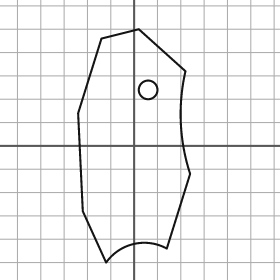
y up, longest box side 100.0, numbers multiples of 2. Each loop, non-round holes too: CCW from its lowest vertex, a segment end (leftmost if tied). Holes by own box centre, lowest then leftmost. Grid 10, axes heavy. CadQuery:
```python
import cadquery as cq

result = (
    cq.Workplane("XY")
    .moveTo(-12.0, -50.0)
    .threePointArc((0.0, -42.0), (14.0, -44.0))
    .lineTo(24.0, -12.0)
    .threePointArc((20.0, 10.0), (22.0, 32.0))
    .lineTo(2.0, 50.0)
    .lineTo(-14.0, 46.0)
    .lineTo(-24.0, 14.0)
    .lineTo(-22.0, -28.0)
    .close()
    .moveTo(6.0, 24.0)
    .circle(4.0)
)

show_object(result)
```